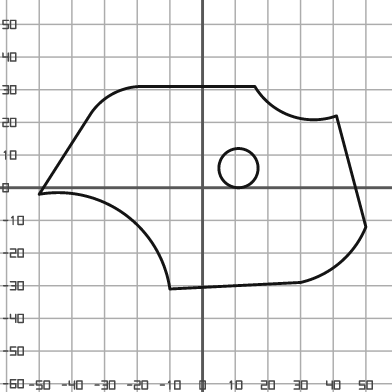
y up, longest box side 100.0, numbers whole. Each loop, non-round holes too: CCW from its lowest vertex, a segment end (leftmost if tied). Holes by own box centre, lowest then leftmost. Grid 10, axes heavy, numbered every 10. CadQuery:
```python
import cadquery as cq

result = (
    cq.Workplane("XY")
    .moveTo(-10.0, -31.0)
    .lineTo(30.0, -29.0)
    .threePointArc((42.0, -23.0), (50.0, -12.0))
    .lineTo(41.0, 22.0)
    .threePointArc((27.0, 22.0), (16.0, 31.0))
    .lineTo(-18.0, 31.0)
    .threePointArc((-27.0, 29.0), (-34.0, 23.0))
    .lineTo(-50.0, -2.0)
    .threePointArc((-24.0, -8.0), (-10.0, -31.0))
    .close()
    .moveTo(11.0, 6.0)
    .circle(6.0)
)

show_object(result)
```